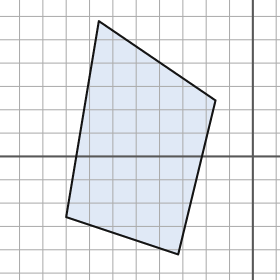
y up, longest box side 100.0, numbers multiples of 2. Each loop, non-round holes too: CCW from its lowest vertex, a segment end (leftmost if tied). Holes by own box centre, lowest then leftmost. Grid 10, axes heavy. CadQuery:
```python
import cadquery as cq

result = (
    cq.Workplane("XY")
    .moveTo(-32.0, -42.0)
    .lineTo(-16.0, 24.0)
    .lineTo(-66.0, 58.0)
    .lineTo(-80.0, -26.0)
    .close()
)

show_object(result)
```